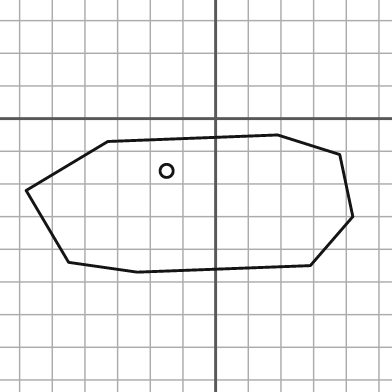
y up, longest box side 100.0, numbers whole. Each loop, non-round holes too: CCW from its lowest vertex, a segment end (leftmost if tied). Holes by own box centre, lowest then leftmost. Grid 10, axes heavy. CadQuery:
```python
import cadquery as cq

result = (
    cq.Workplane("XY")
    .moveTo(-24.0, -47.0)
    .lineTo(29.0, -45.0)
    .lineTo(42.0, -30.0)
    .lineTo(38.0, -11.0)
    .lineTo(19.0, -5.0)
    .lineTo(-33.0, -7.0)
    .lineTo(-58.0, -22.0)
    .lineTo(-45.0, -44.0)
    .close()
    .moveTo(-15.0, -16.0)
    .circle(2.0)
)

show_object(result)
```